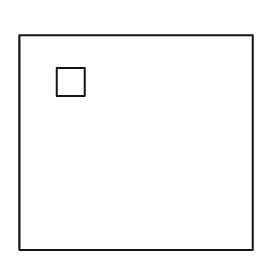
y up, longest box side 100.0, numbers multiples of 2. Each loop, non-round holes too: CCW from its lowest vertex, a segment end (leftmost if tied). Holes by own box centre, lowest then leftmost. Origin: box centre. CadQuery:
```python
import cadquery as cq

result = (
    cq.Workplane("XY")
    .moveTo(-50.0, -46.0)
    .lineTo(50.0, -46.0)
    .lineTo(50.0, 46.0)
    .lineTo(-50.0, 46.0)
    .close()
    .moveTo(-34.0, 20.0)
    .lineTo(-22.0, 20.0)
    .lineTo(-22.0, 32.0)
    .lineTo(-34.0, 32.0)
    .close()
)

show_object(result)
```